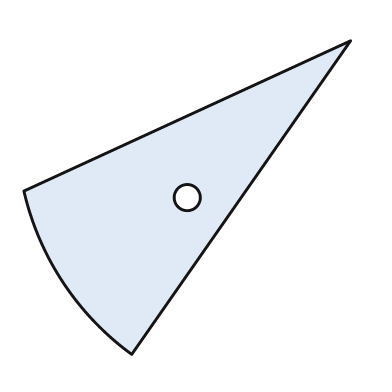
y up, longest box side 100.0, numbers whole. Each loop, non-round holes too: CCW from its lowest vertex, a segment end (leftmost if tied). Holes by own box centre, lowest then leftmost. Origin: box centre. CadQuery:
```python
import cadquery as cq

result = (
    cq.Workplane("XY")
    .moveTo(-17.0, -48.0)
    .lineTo(50.0, 48.0)
    .lineTo(-50.0, 2.0)
    .threePointArc((-38.0, -26.0), (-17.0, -48.0))
    .close()
    .moveTo(0.0, 0.0)
    .circle(4.0)
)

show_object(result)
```